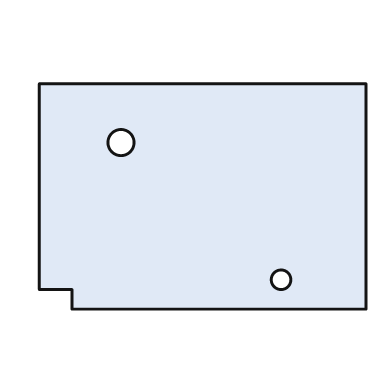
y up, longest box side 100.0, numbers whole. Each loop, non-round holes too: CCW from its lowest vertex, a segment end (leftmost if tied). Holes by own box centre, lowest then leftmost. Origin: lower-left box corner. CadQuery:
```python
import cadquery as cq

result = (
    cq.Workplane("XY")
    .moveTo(10.0, 0.0)
    .lineTo(100.0, 0.0)
    .lineTo(100.0, 69.0)
    .lineTo(0.0, 69.0)
    .lineTo(0.0, 6.0)
    .lineTo(10.0, 6.0)
    .close()
    .moveTo(74.0, 9.0)
    .circle(3.0)
    .moveTo(25.0, 51.0)
    .circle(4.0)
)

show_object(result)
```